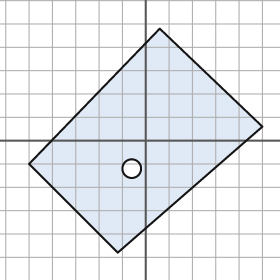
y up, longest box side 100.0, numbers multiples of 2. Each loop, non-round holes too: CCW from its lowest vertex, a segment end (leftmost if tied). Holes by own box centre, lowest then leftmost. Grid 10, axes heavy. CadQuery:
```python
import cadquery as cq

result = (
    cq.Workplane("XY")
    .moveTo(-12.0, -48.0)
    .lineTo(50.0, 6.0)
    .lineTo(6.0, 48.0)
    .lineTo(-50.0, -10.0)
    .close()
    .moveTo(-6.0, -12.0)
    .circle(4.0)
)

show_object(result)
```